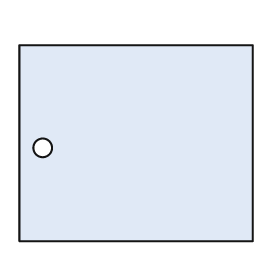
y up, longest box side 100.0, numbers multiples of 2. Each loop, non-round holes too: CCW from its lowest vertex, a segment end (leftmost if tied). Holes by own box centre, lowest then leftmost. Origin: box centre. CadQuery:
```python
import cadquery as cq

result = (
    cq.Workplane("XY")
    .moveTo(-50.0, -42.0)
    .lineTo(50.0, -42.0)
    .lineTo(50.0, 42.0)
    .lineTo(-50.0, 42.0)
    .close()
    .moveTo(-40.0, -2.0)
    .circle(4.0)
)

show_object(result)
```